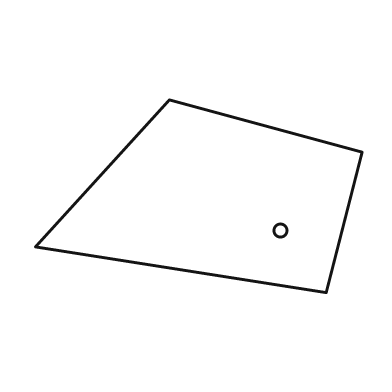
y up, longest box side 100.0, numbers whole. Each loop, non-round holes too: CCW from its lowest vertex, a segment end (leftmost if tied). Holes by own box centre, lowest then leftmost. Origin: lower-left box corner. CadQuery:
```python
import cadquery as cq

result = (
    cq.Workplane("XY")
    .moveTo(89.0, 0.0)
    .lineTo(100.0, 43.0)
    .lineTo(41.0, 59.0)
    .lineTo(0.0, 14.0)
    .close()
    .moveTo(75.0, 19.0)
    .circle(2.0)
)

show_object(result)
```